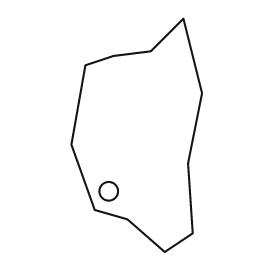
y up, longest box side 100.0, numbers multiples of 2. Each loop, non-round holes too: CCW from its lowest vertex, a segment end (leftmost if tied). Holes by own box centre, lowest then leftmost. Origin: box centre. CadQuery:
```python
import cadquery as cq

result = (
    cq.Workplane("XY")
    .moveTo(12.0, -50.0)
    .lineTo(24.0, -42.0)
    .lineTo(22.0, -12.0)
    .lineTo(28.0, 18.0)
    .lineTo(20.0, 50.0)
    .lineTo(6.0, 36.0)
    .lineTo(-10.0, 34.0)
    .lineTo(-22.0, 30.0)
    .lineTo(-28.0, -4.0)
    .lineTo(-18.0, -32.0)
    .lineTo(-4.0, -36.0)
    .close()
    .moveTo(-12.0, -24.0)
    .circle(4.0)
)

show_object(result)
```